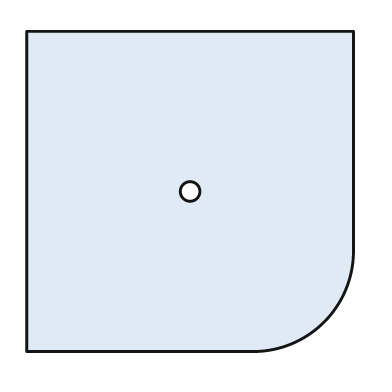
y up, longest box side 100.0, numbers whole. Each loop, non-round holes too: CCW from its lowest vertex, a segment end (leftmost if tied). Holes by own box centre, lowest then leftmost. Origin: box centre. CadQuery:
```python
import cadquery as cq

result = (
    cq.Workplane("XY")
    .moveTo(-50.0, -49.0)
    .lineTo(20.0, -49.0)
    .threePointArc((41.0, -40.0), (50.0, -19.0))
    .lineTo(50.0, 49.0)
    .lineTo(-50.0, 49.0)
    .close()
    .moveTo(0.0, 0.0)
    .circle(3.0)
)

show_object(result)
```